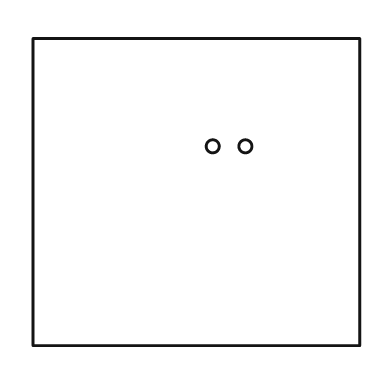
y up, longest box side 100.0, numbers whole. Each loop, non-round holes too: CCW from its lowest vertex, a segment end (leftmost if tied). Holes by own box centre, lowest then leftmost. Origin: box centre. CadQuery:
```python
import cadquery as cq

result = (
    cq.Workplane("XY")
    .moveTo(-50.0, -47.0)
    .lineTo(50.0, -47.0)
    .lineTo(50.0, 47.0)
    .lineTo(-50.0, 47.0)
    .close()
    .moveTo(5.0, 14.0)
    .circle(2.0)
    .moveTo(15.0, 14.0)
    .circle(2.0)
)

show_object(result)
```